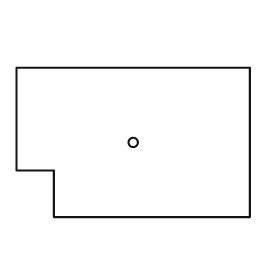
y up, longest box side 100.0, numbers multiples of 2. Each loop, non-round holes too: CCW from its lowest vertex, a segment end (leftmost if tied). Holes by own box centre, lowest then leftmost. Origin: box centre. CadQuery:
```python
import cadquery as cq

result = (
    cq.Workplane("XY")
    .moveTo(-34.0, -32.0)
    .lineTo(50.0, -32.0)
    .lineTo(50.0, 32.0)
    .lineTo(-50.0, 32.0)
    .lineTo(-50.0, -12.0)
    .lineTo(-34.0, -12.0)
    .close()
    .moveTo(0.0, 0.0)
    .circle(2.0)
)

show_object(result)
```